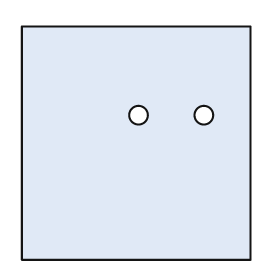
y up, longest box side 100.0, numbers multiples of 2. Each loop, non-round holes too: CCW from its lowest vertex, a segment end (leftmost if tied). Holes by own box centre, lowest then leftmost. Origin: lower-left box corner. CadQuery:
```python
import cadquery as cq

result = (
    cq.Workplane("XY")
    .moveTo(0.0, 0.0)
    .lineTo(98.0, 0.0)
    .lineTo(98.0, 100.0)
    .lineTo(0.0, 100.0)
    .close()
    .moveTo(50.0, 62.0)
    .circle(4.0)
    .moveTo(78.0, 62.0)
    .circle(4.0)
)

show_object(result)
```